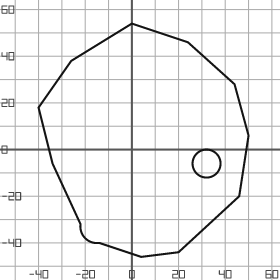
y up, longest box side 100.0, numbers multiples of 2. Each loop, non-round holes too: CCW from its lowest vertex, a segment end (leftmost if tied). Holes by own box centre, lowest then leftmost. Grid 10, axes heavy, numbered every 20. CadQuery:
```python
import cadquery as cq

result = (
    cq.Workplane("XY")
    .moveTo(4.0, -46.0)
    .lineTo(20.0, -44.0)
    .lineTo(46.0, -20.0)
    .lineTo(50.0, 6.0)
    .lineTo(44.0, 28.0)
    .lineTo(24.0, 46.0)
    .lineTo(0.0, 54.0)
    .lineTo(-26.0, 38.0)
    .lineTo(-40.0, 18.0)
    .lineTo(-34.0, -6.0)
    .lineTo(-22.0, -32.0)
    .threePointArc((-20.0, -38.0), (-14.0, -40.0))
    .close()
    .moveTo(32.0, -6.0)
    .circle(6.0)
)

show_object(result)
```